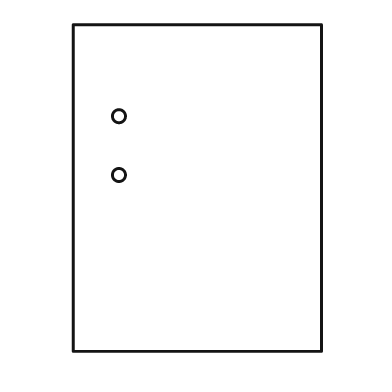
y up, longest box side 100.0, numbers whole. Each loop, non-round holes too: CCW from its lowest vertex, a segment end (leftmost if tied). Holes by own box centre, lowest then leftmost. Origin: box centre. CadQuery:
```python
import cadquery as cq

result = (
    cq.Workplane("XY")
    .moveTo(-38.0, -50.0)
    .lineTo(38.0, -50.0)
    .lineTo(38.0, 50.0)
    .lineTo(-38.0, 50.0)
    .close()
    .moveTo(-24.0, 4.0)
    .circle(2.0)
    .moveTo(-24.0, 22.0)
    .circle(2.0)
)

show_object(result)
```